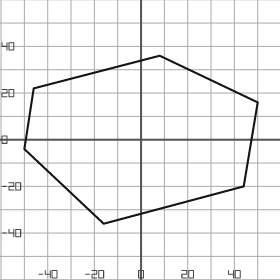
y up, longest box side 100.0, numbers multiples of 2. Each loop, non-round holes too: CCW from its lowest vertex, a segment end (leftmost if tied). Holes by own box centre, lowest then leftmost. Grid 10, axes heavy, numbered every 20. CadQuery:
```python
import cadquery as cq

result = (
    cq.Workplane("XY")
    .moveTo(-16.0, -36.0)
    .lineTo(44.0, -20.0)
    .lineTo(50.0, 16.0)
    .lineTo(8.0, 36.0)
    .lineTo(-46.0, 22.0)
    .lineTo(-50.0, -4.0)
    .close()
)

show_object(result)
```